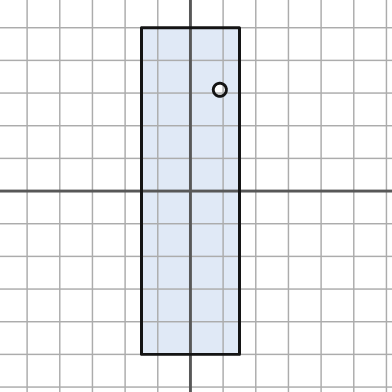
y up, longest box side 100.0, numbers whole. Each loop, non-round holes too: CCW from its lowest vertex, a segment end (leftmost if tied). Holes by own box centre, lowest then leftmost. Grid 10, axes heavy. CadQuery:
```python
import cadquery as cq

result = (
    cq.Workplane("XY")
    .moveTo(-15.0, -50.0)
    .lineTo(15.0, -50.0)
    .lineTo(15.0, 50.0)
    .lineTo(-15.0, 50.0)
    .close()
    .moveTo(9.0, 31.0)
    .circle(2.0)
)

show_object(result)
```